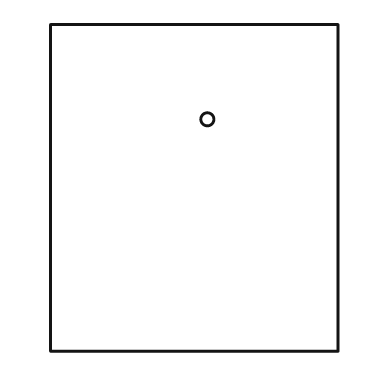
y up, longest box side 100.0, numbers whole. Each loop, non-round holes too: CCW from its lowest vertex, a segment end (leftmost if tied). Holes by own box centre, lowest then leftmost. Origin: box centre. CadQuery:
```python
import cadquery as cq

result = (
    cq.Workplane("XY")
    .moveTo(-44.0, -50.0)
    .lineTo(44.0, -50.0)
    .lineTo(44.0, 50.0)
    .lineTo(-44.0, 50.0)
    .close()
    .moveTo(4.0, 21.0)
    .circle(2.0)
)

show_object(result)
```